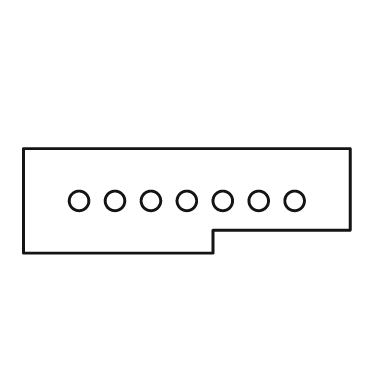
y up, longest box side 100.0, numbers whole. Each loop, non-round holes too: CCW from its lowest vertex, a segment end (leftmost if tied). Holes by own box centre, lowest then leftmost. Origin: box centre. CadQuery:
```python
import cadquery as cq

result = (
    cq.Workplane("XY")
    .moveTo(-50.0, -16.0)
    .lineTo(8.0, -16.0)
    .lineTo(8.0, -9.0)
    .lineTo(50.0, -9.0)
    .lineTo(50.0, 16.0)
    .lineTo(-50.0, 16.0)
    .close()
    .moveTo(-33.0, 0.0)
    .circle(3.0)
    .moveTo(-22.0, 0.0)
    .circle(3.0)
    .moveTo(-11.0, 0.0)
    .circle(3.0)
    .moveTo(0.0, 0.0)
    .circle(3.0)
    .moveTo(11.0, 0.0)
    .circle(3.0)
    .moveTo(22.0, 0.0)
    .circle(3.0)
    .moveTo(33.0, 0.0)
    .circle(3.0)
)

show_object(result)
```